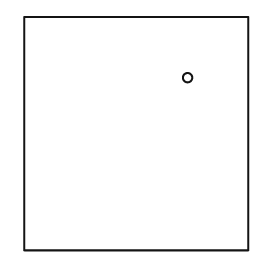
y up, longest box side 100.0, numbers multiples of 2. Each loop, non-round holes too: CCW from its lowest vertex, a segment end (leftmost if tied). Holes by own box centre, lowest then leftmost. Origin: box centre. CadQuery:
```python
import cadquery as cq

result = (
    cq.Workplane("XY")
    .moveTo(-48.0, -50.0)
    .lineTo(48.0, -50.0)
    .lineTo(48.0, 50.0)
    .lineTo(-48.0, 50.0)
    .close()
    .moveTo(22.0, 24.0)
    .circle(2.0)
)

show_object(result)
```